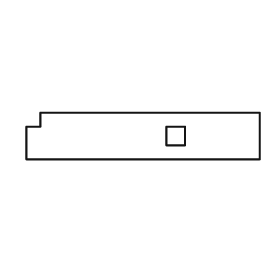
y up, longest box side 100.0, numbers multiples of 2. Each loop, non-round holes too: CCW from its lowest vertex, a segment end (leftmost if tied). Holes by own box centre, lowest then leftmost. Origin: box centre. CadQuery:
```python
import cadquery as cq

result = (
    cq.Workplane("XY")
    .moveTo(-50.0, -10.0)
    .lineTo(50.0, -10.0)
    .lineTo(50.0, 10.0)
    .lineTo(-44.0, 10.0)
    .lineTo(-44.0, 4.0)
    .lineTo(-50.0, 4.0)
    .close()
    .moveTo(10.0, -4.0)
    .lineTo(18.0, -4.0)
    .lineTo(18.0, 4.0)
    .lineTo(10.0, 4.0)
    .close()
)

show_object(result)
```